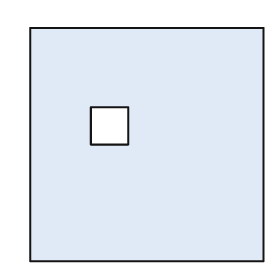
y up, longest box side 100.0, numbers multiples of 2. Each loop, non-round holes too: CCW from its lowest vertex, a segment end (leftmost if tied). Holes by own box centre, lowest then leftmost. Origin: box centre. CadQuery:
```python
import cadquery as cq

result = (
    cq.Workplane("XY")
    .moveTo(-50.0, -50.0)
    .lineTo(50.0, -50.0)
    .lineTo(50.0, 50.0)
    .lineTo(-50.0, 50.0)
    .close()
    .moveTo(-24.0, 0.0)
    .lineTo(-8.0, 0.0)
    .lineTo(-8.0, 16.0)
    .lineTo(-24.0, 16.0)
    .close()
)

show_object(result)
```